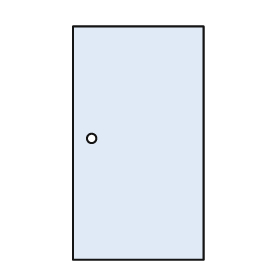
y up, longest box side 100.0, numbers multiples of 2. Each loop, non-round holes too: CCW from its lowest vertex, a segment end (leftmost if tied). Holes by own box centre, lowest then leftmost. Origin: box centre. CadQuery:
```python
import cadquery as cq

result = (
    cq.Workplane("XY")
    .moveTo(-28.0, -50.0)
    .lineTo(28.0, -50.0)
    .lineTo(28.0, 50.0)
    .lineTo(-28.0, 50.0)
    .close()
    .moveTo(-20.0, 2.0)
    .circle(2.0)
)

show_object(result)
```